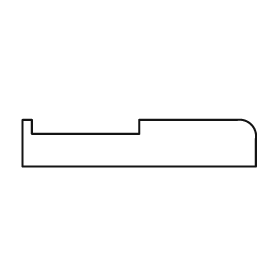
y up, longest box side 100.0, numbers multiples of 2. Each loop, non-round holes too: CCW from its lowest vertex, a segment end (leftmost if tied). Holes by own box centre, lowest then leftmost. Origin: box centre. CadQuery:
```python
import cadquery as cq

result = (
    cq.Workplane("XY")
    .moveTo(-50.0, -10.0)
    .lineTo(50.0, -10.0)
    .lineTo(50.0, 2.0)
    .threePointArc((48.0, 8.0), (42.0, 10.0))
    .lineTo(0.0, 10.0)
    .lineTo(0.0, 4.0)
    .lineTo(-46.0, 4.0)
    .lineTo(-46.0, 10.0)
    .lineTo(-50.0, 10.0)
    .close()
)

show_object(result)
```